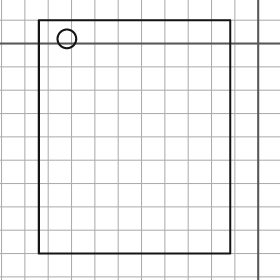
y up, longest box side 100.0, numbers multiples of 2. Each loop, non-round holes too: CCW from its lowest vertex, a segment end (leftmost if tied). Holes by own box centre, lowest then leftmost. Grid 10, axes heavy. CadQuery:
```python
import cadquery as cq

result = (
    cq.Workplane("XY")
    .moveTo(-94.0, -90.0)
    .lineTo(-12.0, -90.0)
    .lineTo(-12.0, 10.0)
    .lineTo(-94.0, 10.0)
    .close()
    .moveTo(-82.0, 2.0)
    .circle(4.0)
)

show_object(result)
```